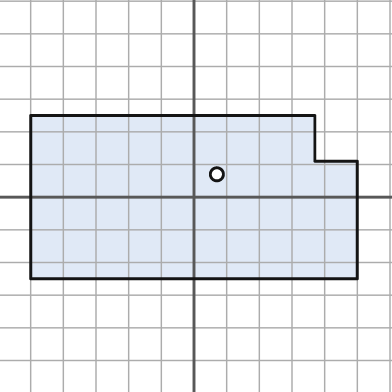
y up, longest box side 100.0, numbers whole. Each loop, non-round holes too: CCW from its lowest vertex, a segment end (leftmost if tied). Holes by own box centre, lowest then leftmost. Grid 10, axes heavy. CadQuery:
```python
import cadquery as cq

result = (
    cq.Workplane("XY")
    .moveTo(-50.0, -25.0)
    .lineTo(50.0, -25.0)
    .lineTo(50.0, 11.0)
    .lineTo(37.0, 11.0)
    .lineTo(37.0, 25.0)
    .lineTo(-50.0, 25.0)
    .close()
    .moveTo(7.0, 7.0)
    .circle(2.0)
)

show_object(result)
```